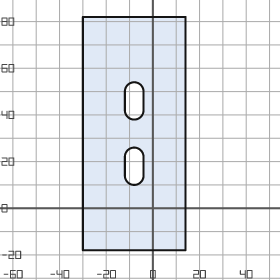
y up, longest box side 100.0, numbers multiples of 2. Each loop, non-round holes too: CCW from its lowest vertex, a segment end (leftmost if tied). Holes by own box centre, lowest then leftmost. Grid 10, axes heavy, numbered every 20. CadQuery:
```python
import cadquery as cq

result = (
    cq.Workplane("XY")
    .moveTo(-30.0, -18.0)
    .lineTo(14.0, -18.0)
    .lineTo(14.0, 82.0)
    .lineTo(-30.0, 82.0)
    .close()
    .moveTo(-12.0, 14.0)
    .threePointArc((-8.0, 10.0), (-4.0, 14.0))
    .lineTo(-4.0, 22.0)
    .threePointArc((-8.0, 26.0), (-12.0, 22.0))
    .close()
    .moveTo(-12.0, 42.0)
    .threePointArc((-8.0, 38.0), (-4.0, 42.0))
    .lineTo(-4.0, 50.0)
    .threePointArc((-8.0, 54.0), (-12.0, 50.0))
    .close()
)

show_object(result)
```